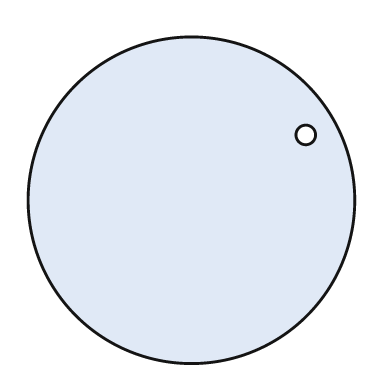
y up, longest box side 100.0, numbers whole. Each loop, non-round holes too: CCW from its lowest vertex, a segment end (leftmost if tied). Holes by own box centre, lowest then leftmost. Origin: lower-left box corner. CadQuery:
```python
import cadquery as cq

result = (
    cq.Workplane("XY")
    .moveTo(50.0, 50.0)
    .circle(50.0)
    .moveTo(85.0, 70.0)
    .circle(3.0)
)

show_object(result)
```